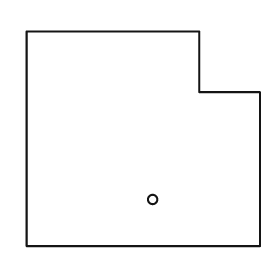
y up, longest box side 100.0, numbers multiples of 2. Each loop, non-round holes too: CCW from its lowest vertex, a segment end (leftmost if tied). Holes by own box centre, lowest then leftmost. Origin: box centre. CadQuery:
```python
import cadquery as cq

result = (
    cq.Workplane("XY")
    .moveTo(-50.0, -46.0)
    .lineTo(50.0, -46.0)
    .lineTo(50.0, 20.0)
    .lineTo(24.0, 20.0)
    .lineTo(24.0, 46.0)
    .lineTo(-50.0, 46.0)
    .close()
    .moveTo(4.0, -26.0)
    .circle(2.0)
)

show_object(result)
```